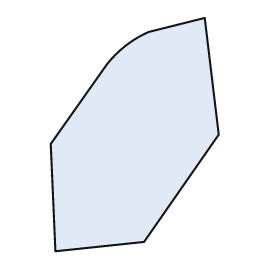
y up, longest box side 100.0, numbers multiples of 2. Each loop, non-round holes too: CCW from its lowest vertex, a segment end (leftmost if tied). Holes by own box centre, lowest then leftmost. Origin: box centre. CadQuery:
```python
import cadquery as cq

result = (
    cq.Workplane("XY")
    .moveTo(-34.0, -50.0)
    .lineTo(4.0, -46.0)
    .lineTo(36.0, 0.0)
    .lineTo(30.0, 50.0)
    .lineTo(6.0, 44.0)
    .threePointArc((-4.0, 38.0), (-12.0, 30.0))
    .lineTo(-36.0, -4.0)
    .close()
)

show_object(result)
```